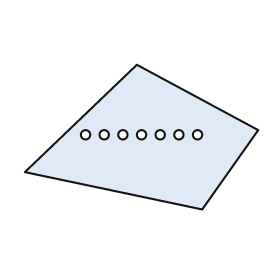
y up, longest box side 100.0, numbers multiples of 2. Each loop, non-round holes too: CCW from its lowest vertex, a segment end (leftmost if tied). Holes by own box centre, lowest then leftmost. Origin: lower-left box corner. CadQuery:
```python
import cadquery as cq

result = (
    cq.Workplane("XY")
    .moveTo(76.0, 0.0)
    .lineTo(100.0, 34.0)
    .lineTo(48.0, 62.0)
    .lineTo(0.0, 16.0)
    .close()
    .moveTo(26.0, 32.0)
    .circle(2.0)
    .moveTo(34.0, 32.0)
    .circle(2.0)
    .moveTo(42.0, 32.0)
    .circle(2.0)
    .moveTo(50.0, 32.0)
    .circle(2.0)
    .moveTo(58.0, 32.0)
    .circle(2.0)
    .moveTo(66.0, 32.0)
    .circle(2.0)
    .moveTo(74.0, 32.0)
    .circle(2.0)
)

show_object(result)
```